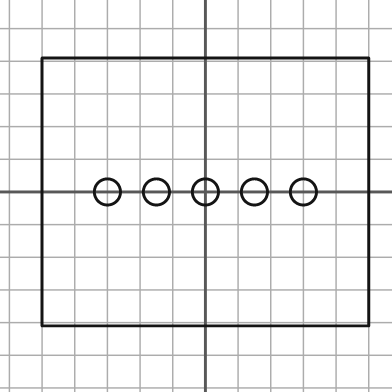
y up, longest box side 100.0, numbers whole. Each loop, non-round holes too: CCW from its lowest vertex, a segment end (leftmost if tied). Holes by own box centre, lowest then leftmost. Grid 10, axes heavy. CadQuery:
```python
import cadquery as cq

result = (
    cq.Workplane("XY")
    .moveTo(-50.0, -41.0)
    .lineTo(50.0, -41.0)
    .lineTo(50.0, 41.0)
    .lineTo(-50.0, 41.0)
    .close()
    .moveTo(-30.0, 0.0)
    .circle(4.0)
    .moveTo(-15.0, 0.0)
    .circle(4.0)
    .moveTo(0.0, 0.0)
    .circle(4.0)
    .moveTo(15.0, 0.0)
    .circle(4.0)
    .moveTo(30.0, 0.0)
    .circle(4.0)
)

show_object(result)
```